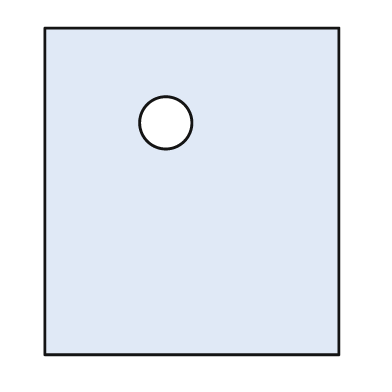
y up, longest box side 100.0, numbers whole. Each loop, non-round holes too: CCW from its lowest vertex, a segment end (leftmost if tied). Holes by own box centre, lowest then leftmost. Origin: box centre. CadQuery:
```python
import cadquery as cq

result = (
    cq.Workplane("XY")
    .moveTo(-45.0, -50.0)
    .lineTo(45.0, -50.0)
    .lineTo(45.0, 50.0)
    .lineTo(-45.0, 50.0)
    .close()
    .moveTo(-8.0, 21.0)
    .circle(8.0)
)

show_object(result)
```